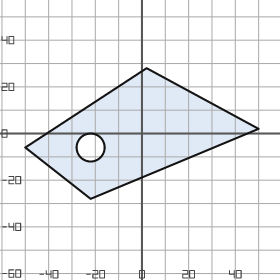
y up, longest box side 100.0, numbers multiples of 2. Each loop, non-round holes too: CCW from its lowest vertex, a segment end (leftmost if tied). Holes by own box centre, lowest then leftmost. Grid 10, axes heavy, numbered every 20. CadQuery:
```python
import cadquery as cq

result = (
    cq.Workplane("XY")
    .moveTo(-22.0, -28.0)
    .lineTo(50.0, 2.0)
    .lineTo(2.0, 28.0)
    .lineTo(-50.0, -6.0)
    .close()
    .moveTo(-22.0, -6.0)
    .circle(6.0)
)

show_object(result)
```